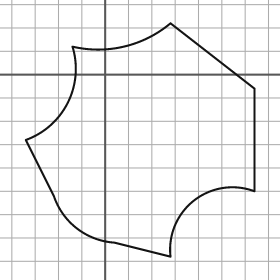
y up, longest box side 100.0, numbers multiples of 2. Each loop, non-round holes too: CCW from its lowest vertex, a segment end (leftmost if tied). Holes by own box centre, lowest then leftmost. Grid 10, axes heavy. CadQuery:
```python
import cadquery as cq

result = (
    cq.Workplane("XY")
    .moveTo(28.0, -78.0)
    .threePointArc((38.0, -54.0), (64.0, -50.0))
    .lineTo(64.0, -6.0)
    .lineTo(28.0, 22.0)
    .threePointArc((8.0, 12.0), (-14.0, 12.0))
    .threePointArc((-16.0, -12.0), (-34.0, -28.0))
    .lineTo(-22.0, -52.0)
    .threePointArc((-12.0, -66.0), (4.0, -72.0))
    .close()
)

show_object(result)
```